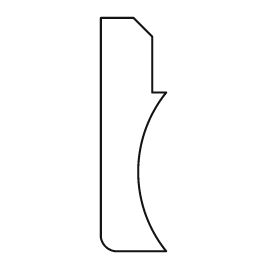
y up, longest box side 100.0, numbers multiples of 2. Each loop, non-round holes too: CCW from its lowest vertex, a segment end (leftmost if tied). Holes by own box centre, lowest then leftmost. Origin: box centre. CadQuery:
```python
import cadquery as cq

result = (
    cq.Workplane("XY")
    .moveTo(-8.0, -50.0)
    .lineTo(14.0, -50.0)
    .threePointArc((2.0, -16.0), (14.0, 18.0))
    .lineTo(8.0, 18.0)
    .lineTo(8.0, 42.0)
    .lineTo(0.0, 50.0)
    .lineTo(-14.0, 50.0)
    .lineTo(-14.0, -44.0)
    .threePointArc((-12.0, -48.0), (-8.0, -50.0))
    .close()
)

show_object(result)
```